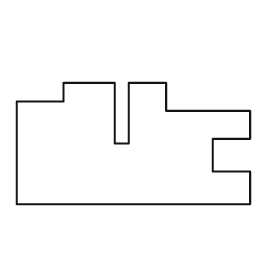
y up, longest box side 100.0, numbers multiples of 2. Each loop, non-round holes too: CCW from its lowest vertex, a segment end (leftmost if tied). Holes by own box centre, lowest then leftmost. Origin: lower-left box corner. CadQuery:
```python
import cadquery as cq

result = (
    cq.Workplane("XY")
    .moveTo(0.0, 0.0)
    .lineTo(100.0, 0.0)
    .lineTo(100.0, 14.0)
    .lineTo(84.0, 14.0)
    .lineTo(84.0, 28.0)
    .lineTo(100.0, 28.0)
    .lineTo(100.0, 40.0)
    .lineTo(64.0, 40.0)
    .lineTo(64.0, 52.0)
    .lineTo(48.0, 52.0)
    .lineTo(48.0, 26.0)
    .lineTo(42.0, 26.0)
    .lineTo(42.0, 52.0)
    .lineTo(20.0, 52.0)
    .lineTo(20.0, 44.0)
    .lineTo(0.0, 44.0)
    .close()
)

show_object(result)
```